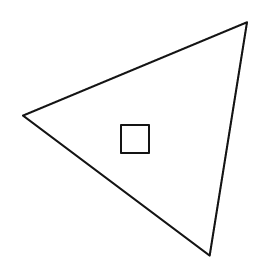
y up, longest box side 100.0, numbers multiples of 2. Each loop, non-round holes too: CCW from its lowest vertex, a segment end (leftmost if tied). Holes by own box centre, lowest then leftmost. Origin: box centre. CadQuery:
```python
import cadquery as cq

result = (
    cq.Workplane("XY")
    .moveTo(32.0, -50.0)
    .lineTo(48.0, 50.0)
    .lineTo(-48.0, 10.0)
    .close()
    .moveTo(-6.0, -6.0)
    .lineTo(6.0, -6.0)
    .lineTo(6.0, 6.0)
    .lineTo(-6.0, 6.0)
    .close()
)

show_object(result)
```